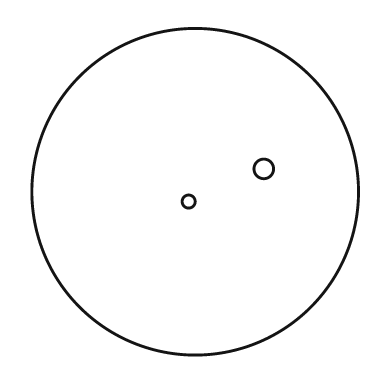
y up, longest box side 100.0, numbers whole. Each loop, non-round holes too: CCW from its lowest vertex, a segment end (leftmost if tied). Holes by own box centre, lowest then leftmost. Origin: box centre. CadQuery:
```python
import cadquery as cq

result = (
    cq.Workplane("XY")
    .moveTo(0.0, 0.0)
    .circle(50.0)
    .moveTo(-2.0, -3.0)
    .circle(2.0)
    .moveTo(21.0, 7.0)
    .circle(3.0)
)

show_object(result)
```